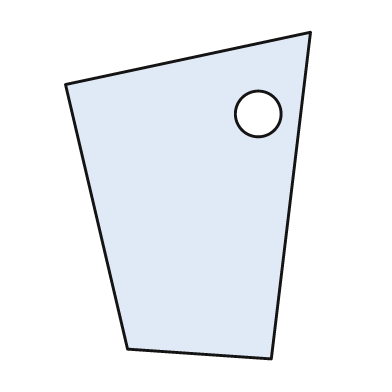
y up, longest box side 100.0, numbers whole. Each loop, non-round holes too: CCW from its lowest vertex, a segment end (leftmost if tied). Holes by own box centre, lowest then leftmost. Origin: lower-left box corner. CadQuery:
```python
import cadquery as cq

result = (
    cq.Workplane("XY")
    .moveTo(63.0, 0.0)
    .lineTo(75.0, 100.0)
    .lineTo(0.0, 84.0)
    .lineTo(19.0, 3.0)
    .close()
    .moveTo(59.0, 75.0)
    .circle(7.0)
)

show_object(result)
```